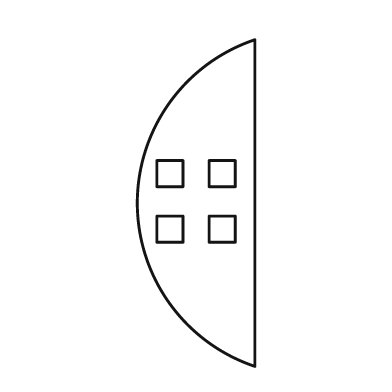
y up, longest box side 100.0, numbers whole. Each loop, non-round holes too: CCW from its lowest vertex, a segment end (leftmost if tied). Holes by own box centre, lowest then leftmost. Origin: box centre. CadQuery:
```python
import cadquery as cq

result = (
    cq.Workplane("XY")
    .moveTo(18.0, -50.0)
    .lineTo(18.0, 50.0)
    .threePointArc((-18.0, 0.0), (18.0, -50.0))
    .close()
    .moveTo(-12.0, -12.0)
    .lineTo(-4.0, -12.0)
    .lineTo(-4.0, -4.0)
    .lineTo(-12.0, -4.0)
    .close()
    .moveTo(4.0, -12.0)
    .lineTo(12.0, -12.0)
    .lineTo(12.0, -4.0)
    .lineTo(4.0, -4.0)
    .close()
    .moveTo(-12.0, 5.0)
    .lineTo(-4.0, 5.0)
    .lineTo(-4.0, 13.0)
    .lineTo(-12.0, 13.0)
    .close()
    .moveTo(4.0, 5.0)
    .lineTo(12.0, 5.0)
    .lineTo(12.0, 13.0)
    .lineTo(4.0, 13.0)
    .close()
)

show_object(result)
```